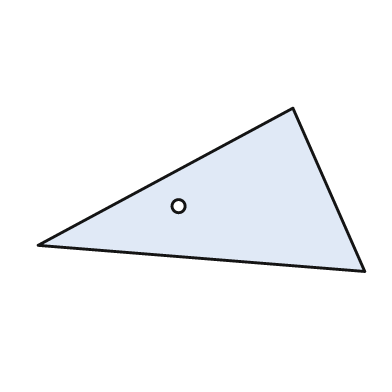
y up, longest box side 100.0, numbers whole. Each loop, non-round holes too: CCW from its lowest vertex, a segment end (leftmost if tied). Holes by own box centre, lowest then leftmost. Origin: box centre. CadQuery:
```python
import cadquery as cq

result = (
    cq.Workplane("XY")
    .moveTo(50.0, -25.0)
    .lineTo(28.0, 25.0)
    .lineTo(-50.0, -17.0)
    .close()
    .moveTo(-7.0, -5.0)
    .circle(2.0)
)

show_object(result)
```